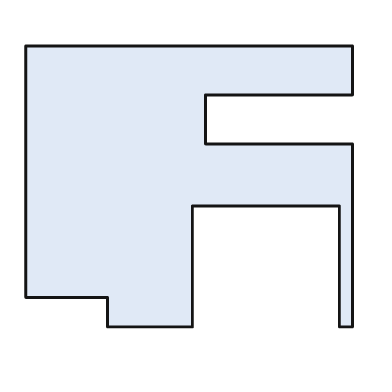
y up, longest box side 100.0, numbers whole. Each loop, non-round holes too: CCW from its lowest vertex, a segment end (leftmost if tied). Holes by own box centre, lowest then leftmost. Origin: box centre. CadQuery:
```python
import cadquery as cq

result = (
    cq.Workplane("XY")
    .moveTo(-25.0, -43.0)
    .lineTo(1.0, -43.0)
    .lineTo(1.0, -6.0)
    .lineTo(46.0, -6.0)
    .lineTo(46.0, -43.0)
    .lineTo(50.0, -43.0)
    .lineTo(50.0, 13.0)
    .lineTo(5.0, 13.0)
    .lineTo(5.0, 28.0)
    .lineTo(50.0, 28.0)
    .lineTo(50.0, 43.0)
    .lineTo(-50.0, 43.0)
    .lineTo(-50.0, -34.0)
    .lineTo(-25.0, -34.0)
    .close()
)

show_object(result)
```